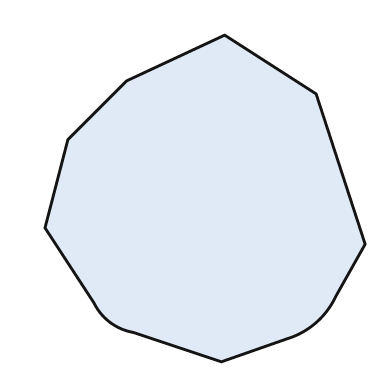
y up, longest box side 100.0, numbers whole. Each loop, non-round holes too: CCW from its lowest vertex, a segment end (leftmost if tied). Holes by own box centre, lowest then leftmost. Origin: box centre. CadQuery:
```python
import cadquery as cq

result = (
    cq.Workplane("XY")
    .moveTo(5.0, -50.0)
    .lineTo(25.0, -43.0)
    .threePointArc((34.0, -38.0), (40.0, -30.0))
    .lineTo(49.0, -14.0)
    .lineTo(34.0, 32.0)
    .lineTo(6.0, 50.0)
    .lineTo(-24.0, 36.0)
    .lineTo(-42.0, 18.0)
    .lineTo(-49.0, -9.0)
    .lineTo(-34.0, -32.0)
    .threePointArc((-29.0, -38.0), (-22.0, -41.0))
    .close()
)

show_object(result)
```